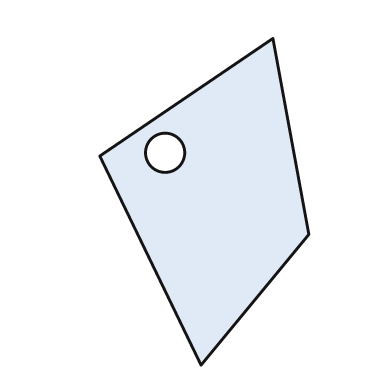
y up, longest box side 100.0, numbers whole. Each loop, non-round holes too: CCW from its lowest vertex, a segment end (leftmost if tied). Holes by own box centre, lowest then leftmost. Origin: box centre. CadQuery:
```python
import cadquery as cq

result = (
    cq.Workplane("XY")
    .moveTo(-1.0, -50.0)
    .lineTo(32.0, -10.0)
    .lineTo(21.0, 50.0)
    .lineTo(-32.0, 14.0)
    .close()
    .moveTo(-12.0, 15.0)
    .circle(6.0)
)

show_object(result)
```